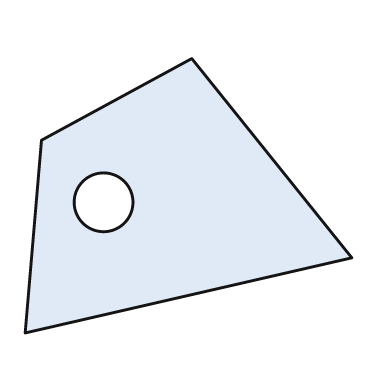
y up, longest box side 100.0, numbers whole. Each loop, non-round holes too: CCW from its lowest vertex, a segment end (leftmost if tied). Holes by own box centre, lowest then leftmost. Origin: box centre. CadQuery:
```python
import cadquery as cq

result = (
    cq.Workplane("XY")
    .moveTo(-50.0, -42.0)
    .lineTo(50.0, -19.0)
    .lineTo(1.0, 42.0)
    .lineTo(-45.0, 17.0)
    .close()
    .moveTo(-26.0, -2.0)
    .circle(9.0)
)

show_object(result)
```